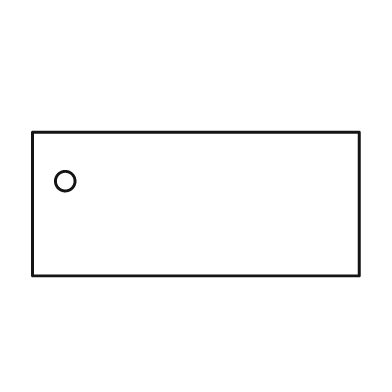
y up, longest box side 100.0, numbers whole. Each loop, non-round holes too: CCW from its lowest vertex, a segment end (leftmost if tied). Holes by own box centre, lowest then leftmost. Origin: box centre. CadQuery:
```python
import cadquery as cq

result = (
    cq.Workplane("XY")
    .moveTo(-50.0, -22.0)
    .lineTo(50.0, -22.0)
    .lineTo(50.0, 22.0)
    .lineTo(-50.0, 22.0)
    .close()
    .moveTo(-40.0, 7.0)
    .circle(3.0)
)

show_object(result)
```